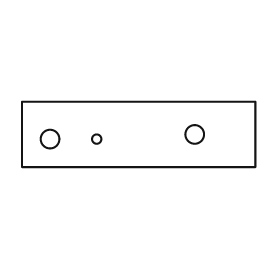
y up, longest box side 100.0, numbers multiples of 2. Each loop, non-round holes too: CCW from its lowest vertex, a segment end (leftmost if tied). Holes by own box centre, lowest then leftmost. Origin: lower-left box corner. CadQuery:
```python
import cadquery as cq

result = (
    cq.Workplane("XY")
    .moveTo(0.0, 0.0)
    .lineTo(100.0, 0.0)
    .lineTo(100.0, 28.0)
    .lineTo(0.0, 28.0)
    .close()
    .moveTo(12.0, 12.0)
    .circle(4.0)
    .moveTo(32.0, 12.0)
    .circle(2.0)
    .moveTo(74.0, 14.0)
    .circle(4.0)
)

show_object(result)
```